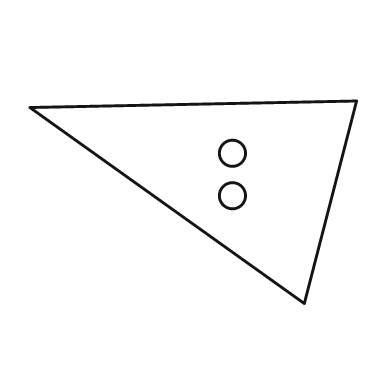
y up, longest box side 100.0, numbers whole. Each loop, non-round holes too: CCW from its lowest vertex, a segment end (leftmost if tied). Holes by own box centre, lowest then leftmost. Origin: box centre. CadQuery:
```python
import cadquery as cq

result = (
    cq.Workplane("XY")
    .moveTo(34.0, -31.0)
    .lineTo(50.0, 31.0)
    .lineTo(-50.0, 29.0)
    .close()
    .moveTo(12.0, 2.0)
    .circle(4.0)
    .moveTo(12.0, 15.0)
    .circle(4.0)
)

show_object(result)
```